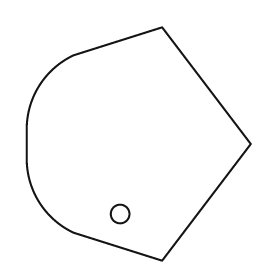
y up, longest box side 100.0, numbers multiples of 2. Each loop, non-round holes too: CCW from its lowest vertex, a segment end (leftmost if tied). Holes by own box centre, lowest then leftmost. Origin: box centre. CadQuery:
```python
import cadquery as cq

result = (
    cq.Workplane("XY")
    .moveTo(10.0, -50.0)
    .lineTo(48.0, 0.0)
    .lineTo(10.0, 50.0)
    .lineTo(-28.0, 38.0)
    .threePointArc((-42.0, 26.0), (-48.0, 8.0))
    .lineTo(-48.0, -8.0)
    .threePointArc((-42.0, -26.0), (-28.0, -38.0))
    .close()
    .moveTo(-8.0, -30.0)
    .circle(4.0)
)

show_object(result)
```